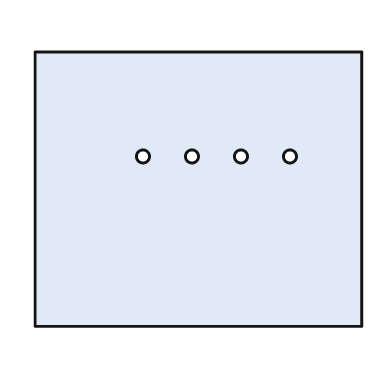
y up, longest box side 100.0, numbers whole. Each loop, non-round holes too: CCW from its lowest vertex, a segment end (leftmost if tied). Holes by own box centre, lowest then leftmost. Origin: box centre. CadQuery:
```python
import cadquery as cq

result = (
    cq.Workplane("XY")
    .moveTo(-50.0, -42.0)
    .lineTo(50.0, -42.0)
    .lineTo(50.0, 42.0)
    .lineTo(-50.0, 42.0)
    .close()
    .moveTo(-17.0, 10.0)
    .circle(2.0)
    .moveTo(-2.0, 10.0)
    .circle(2.0)
    .moveTo(13.0, 10.0)
    .circle(2.0)
    .moveTo(28.0, 10.0)
    .circle(2.0)
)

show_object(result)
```